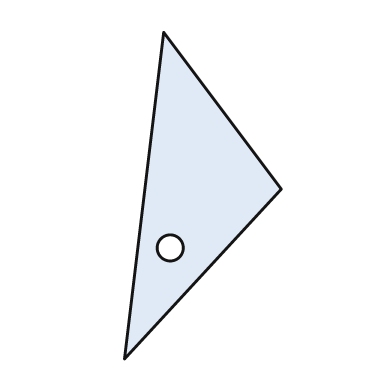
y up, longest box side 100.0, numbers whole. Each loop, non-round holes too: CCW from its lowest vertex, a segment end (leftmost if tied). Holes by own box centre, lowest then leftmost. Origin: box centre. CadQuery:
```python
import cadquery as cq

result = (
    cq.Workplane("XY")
    .moveTo(-24.0, -50.0)
    .lineTo(24.0, 2.0)
    .lineTo(-12.0, 50.0)
    .close()
    .moveTo(-10.0, -16.0)
    .circle(4.0)
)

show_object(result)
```